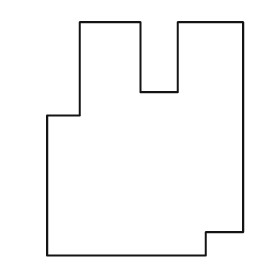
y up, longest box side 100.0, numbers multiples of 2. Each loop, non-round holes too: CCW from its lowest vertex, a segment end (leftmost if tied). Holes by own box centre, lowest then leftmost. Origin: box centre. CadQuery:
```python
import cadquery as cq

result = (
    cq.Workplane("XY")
    .moveTo(-42.0, -50.0)
    .lineTo(26.0, -50.0)
    .lineTo(26.0, -40.0)
    .lineTo(42.0, -40.0)
    .lineTo(42.0, 50.0)
    .lineTo(14.0, 50.0)
    .lineTo(14.0, 20.0)
    .lineTo(-2.0, 20.0)
    .lineTo(-2.0, 50.0)
    .lineTo(-28.0, 50.0)
    .lineTo(-28.0, 10.0)
    .lineTo(-42.0, 10.0)
    .close()
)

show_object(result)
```